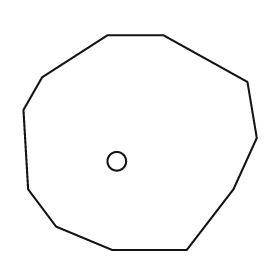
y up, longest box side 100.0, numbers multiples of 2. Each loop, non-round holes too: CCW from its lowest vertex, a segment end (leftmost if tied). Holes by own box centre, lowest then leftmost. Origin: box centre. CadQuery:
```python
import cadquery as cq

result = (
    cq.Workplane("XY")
    .moveTo(-12.0, -46.0)
    .lineTo(20.0, -46.0)
    .lineTo(40.0, -20.0)
    .lineTo(50.0, 2.0)
    .lineTo(46.0, 26.0)
    .lineTo(10.0, 46.0)
    .lineTo(-14.0, 46.0)
    .lineTo(-42.0, 28.0)
    .lineTo(-50.0, 14.0)
    .lineTo(-48.0, -20.0)
    .lineTo(-36.0, -36.0)
    .close()
    .moveTo(-10.0, -8.0)
    .circle(4.0)
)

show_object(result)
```